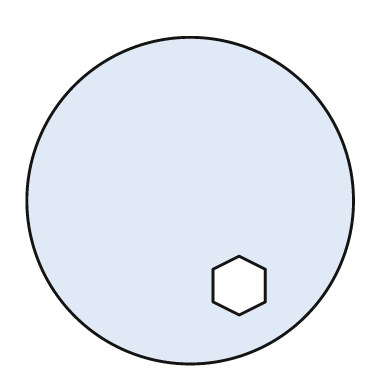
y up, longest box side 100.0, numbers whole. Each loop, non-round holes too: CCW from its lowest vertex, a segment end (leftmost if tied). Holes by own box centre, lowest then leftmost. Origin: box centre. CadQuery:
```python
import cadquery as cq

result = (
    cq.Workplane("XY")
    .moveTo(0.0, 0.0)
    .circle(50.0)
    .moveTo(15.0, -35.0)
    .lineTo(23.0, -31.0)
    .lineTo(23.0, -21.0)
    .lineTo(15.0, -17.0)
    .lineTo(7.0, -21.0)
    .lineTo(7.0, -31.0)
    .close()
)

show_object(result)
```